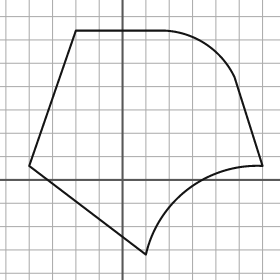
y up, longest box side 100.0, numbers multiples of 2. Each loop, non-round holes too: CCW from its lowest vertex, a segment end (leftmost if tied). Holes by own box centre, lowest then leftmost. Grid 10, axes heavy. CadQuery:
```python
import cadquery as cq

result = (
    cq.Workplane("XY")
    .moveTo(10.0, -32.0)
    .threePointArc((28.0, -4.0), (60.0, 6.0))
    .lineTo(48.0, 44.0)
    .threePointArc((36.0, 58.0), (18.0, 64.0))
    .lineTo(-20.0, 64.0)
    .lineTo(-40.0, 6.0)
    .close()
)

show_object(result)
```